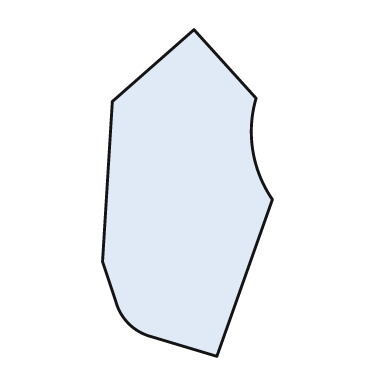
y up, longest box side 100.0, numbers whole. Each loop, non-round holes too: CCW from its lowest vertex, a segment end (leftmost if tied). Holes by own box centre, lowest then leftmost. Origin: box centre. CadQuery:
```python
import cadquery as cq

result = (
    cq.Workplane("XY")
    .moveTo(9.0, -50.0)
    .lineTo(26.0, -2.0)
    .threePointArc((20.0, 13.0), (21.0, 29.0))
    .lineTo(2.0, 50.0)
    .lineTo(-23.0, 28.0)
    .lineTo(-26.0, -21.0)
    .lineTo(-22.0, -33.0)
    .threePointArc((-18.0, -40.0), (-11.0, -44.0))
    .close()
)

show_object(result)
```